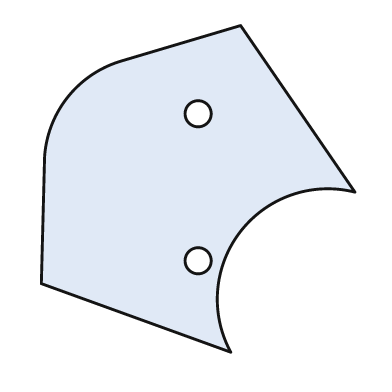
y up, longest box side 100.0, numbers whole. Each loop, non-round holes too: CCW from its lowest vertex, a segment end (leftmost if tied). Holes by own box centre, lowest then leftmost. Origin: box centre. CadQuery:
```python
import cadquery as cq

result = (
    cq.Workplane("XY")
    .moveTo(10.0, -50.0)
    .threePointArc((13.0, -13.0), (48.0, -1.0))
    .lineTo(13.0, 50.0)
    .lineTo(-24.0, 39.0)
    .threePointArc((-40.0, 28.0), (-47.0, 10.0))
    .lineTo(-48.0, -29.0)
    .close()
    .moveTo(0.0, -22.0)
    .circle(4.0)
    .moveTo(0.0, 23.0)
    .circle(4.0)
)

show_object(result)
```